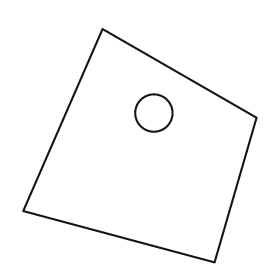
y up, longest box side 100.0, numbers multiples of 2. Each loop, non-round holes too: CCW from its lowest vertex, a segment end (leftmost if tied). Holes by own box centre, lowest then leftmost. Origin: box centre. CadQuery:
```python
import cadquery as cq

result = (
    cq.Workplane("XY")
    .moveTo(32.0, -50.0)
    .lineTo(50.0, 12.0)
    .lineTo(-16.0, 50.0)
    .lineTo(-50.0, -28.0)
    .close()
    .moveTo(6.0, 14.0)
    .circle(8.0)
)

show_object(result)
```